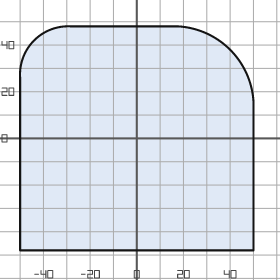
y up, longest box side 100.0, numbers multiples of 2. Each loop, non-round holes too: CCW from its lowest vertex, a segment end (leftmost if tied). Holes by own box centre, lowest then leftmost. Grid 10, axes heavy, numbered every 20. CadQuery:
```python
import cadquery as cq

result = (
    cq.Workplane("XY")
    .moveTo(-50.0, -48.0)
    .lineTo(50.0, -48.0)
    .lineTo(50.0, 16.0)
    .threePointArc((40.0, 38.0), (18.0, 48.0))
    .lineTo(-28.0, 48.0)
    .threePointArc((-44.0, 42.0), (-50.0, 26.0))
    .close()
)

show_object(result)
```